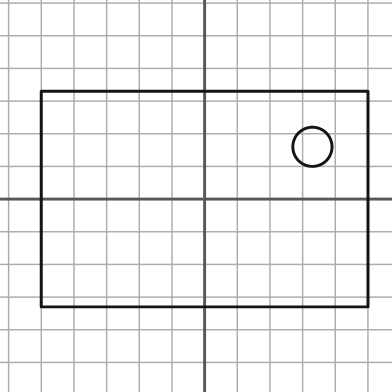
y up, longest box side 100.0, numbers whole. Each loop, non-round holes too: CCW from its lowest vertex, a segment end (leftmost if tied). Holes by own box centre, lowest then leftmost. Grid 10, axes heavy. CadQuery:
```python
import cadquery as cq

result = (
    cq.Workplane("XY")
    .moveTo(-50.0, -33.0)
    .lineTo(50.0, -33.0)
    .lineTo(50.0, 33.0)
    .lineTo(-50.0, 33.0)
    .close()
    .moveTo(33.0, 16.0)
    .circle(6.0)
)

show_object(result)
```